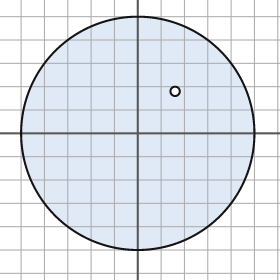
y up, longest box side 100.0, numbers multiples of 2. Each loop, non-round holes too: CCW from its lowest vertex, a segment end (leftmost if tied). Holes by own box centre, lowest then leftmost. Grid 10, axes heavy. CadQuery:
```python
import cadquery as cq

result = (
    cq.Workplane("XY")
    .moveTo(0.0, 0.0)
    .circle(50.0)
    .moveTo(16.0, 18.0)
    .circle(2.0)
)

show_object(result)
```